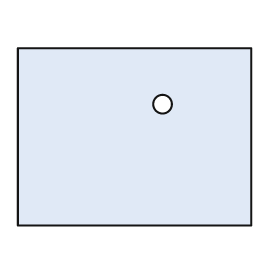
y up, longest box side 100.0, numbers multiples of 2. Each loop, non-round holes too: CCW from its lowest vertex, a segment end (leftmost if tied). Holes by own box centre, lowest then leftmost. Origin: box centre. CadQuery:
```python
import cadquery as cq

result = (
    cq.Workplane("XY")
    .moveTo(-50.0, -38.0)
    .lineTo(50.0, -38.0)
    .lineTo(50.0, 38.0)
    .lineTo(-50.0, 38.0)
    .close()
    .moveTo(12.0, 14.0)
    .circle(4.0)
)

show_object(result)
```